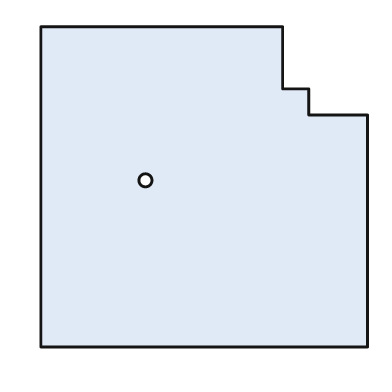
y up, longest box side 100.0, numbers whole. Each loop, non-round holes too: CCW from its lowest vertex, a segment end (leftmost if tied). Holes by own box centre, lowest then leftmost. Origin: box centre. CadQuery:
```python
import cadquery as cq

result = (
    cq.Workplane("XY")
    .moveTo(-50.0, -49.0)
    .lineTo(50.0, -49.0)
    .lineTo(50.0, 22.0)
    .lineTo(32.0, 22.0)
    .lineTo(32.0, 30.0)
    .lineTo(24.0, 30.0)
    .lineTo(24.0, 49.0)
    .lineTo(-50.0, 49.0)
    .close()
    .moveTo(-18.0, 2.0)
    .circle(2.0)
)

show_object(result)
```